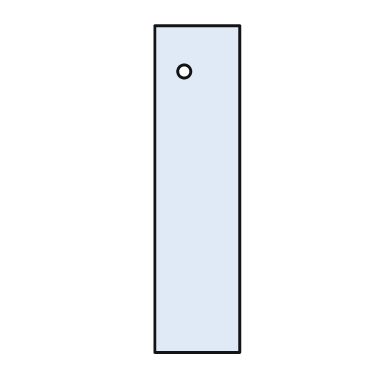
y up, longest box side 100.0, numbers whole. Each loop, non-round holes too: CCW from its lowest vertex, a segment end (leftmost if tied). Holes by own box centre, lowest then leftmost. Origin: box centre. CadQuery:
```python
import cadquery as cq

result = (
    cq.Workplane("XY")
    .moveTo(-13.0, -50.0)
    .lineTo(13.0, -50.0)
    .lineTo(13.0, 50.0)
    .lineTo(-13.0, 50.0)
    .close()
    .moveTo(-4.0, 36.0)
    .circle(2.0)
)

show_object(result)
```